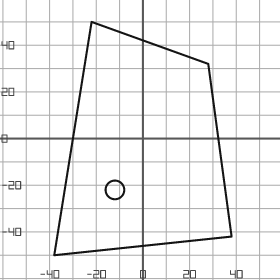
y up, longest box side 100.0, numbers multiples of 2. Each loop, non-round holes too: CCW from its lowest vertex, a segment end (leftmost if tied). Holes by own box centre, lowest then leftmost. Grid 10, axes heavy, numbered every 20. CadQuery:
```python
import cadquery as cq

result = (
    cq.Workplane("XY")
    .moveTo(-38.0, -50.0)
    .lineTo(38.0, -42.0)
    .lineTo(28.0, 32.0)
    .lineTo(-22.0, 50.0)
    .close()
    .moveTo(-12.0, -22.0)
    .circle(4.0)
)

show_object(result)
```